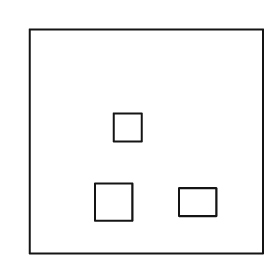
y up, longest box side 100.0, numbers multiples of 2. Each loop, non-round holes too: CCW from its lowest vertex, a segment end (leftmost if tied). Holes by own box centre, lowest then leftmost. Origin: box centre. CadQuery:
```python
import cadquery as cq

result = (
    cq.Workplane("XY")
    .moveTo(-50.0, -48.0)
    .lineTo(50.0, -48.0)
    .lineTo(50.0, 48.0)
    .lineTo(-50.0, 48.0)
    .close()
    .moveTo(-22.0, -34.0)
    .lineTo(-6.0, -34.0)
    .lineTo(-6.0, -18.0)
    .lineTo(-22.0, -18.0)
    .close()
    .moveTo(14.0, -32.0)
    .lineTo(30.0, -32.0)
    .lineTo(30.0, -20.0)
    .lineTo(14.0, -20.0)
    .close()
    .moveTo(-14.0, 0.0)
    .lineTo(-2.0, 0.0)
    .lineTo(-2.0, 12.0)
    .lineTo(-14.0, 12.0)
    .close()
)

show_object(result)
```